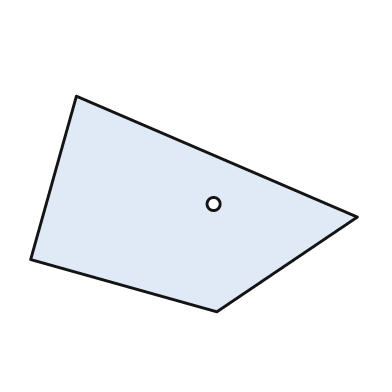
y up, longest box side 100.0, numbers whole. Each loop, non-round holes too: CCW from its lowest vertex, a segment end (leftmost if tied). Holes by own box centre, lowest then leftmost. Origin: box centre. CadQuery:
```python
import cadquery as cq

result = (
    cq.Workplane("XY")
    .moveTo(7.0, -33.0)
    .lineTo(50.0, -4.0)
    .lineTo(-36.0, 33.0)
    .lineTo(-50.0, -17.0)
    .close()
    .moveTo(6.0, 0.0)
    .circle(2.0)
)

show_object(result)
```